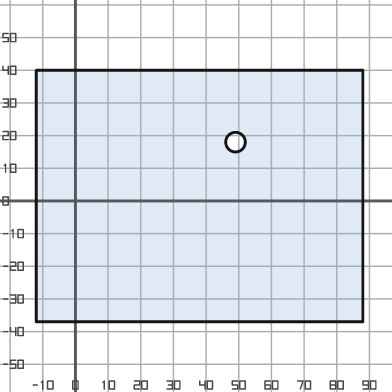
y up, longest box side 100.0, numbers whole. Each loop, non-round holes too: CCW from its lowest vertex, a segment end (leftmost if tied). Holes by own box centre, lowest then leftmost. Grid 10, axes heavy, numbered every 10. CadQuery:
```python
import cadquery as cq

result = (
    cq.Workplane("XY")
    .moveTo(-12.0, -37.0)
    .lineTo(88.0, -37.0)
    .lineTo(88.0, 40.0)
    .lineTo(-12.0, 40.0)
    .close()
    .moveTo(49.0, 18.0)
    .circle(3.0)
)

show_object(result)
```